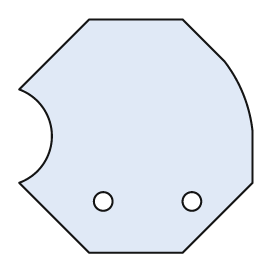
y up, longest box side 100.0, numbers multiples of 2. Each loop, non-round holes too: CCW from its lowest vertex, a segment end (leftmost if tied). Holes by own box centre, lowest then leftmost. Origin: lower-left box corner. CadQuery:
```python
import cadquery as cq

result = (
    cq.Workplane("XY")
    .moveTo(30.0, 0.0)
    .lineTo(70.0, 0.0)
    .lineTo(100.0, 30.0)
    .lineTo(100.0, 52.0)
    .threePointArc((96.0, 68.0), (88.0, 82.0))
    .lineTo(70.0, 100.0)
    .lineTo(30.0, 100.0)
    .lineTo(0.0, 70.0)
    .threePointArc((14.0, 50.0), (0.0, 30.0))
    .close()
    .moveTo(36.0, 22.0)
    .circle(4.0)
    .moveTo(74.0, 22.0)
    .circle(4.0)
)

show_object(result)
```